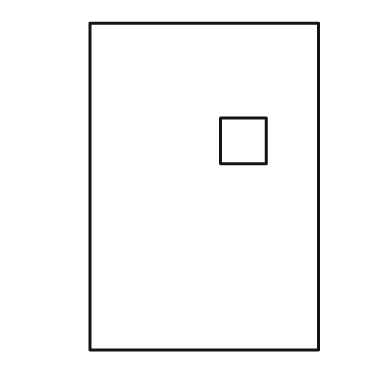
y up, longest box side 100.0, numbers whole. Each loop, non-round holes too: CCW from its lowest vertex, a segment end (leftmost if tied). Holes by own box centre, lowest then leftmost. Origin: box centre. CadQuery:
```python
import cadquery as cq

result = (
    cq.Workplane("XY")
    .moveTo(-35.0, -50.0)
    .lineTo(35.0, -50.0)
    .lineTo(35.0, 50.0)
    .lineTo(-35.0, 50.0)
    .close()
    .moveTo(5.0, 7.0)
    .lineTo(19.0, 7.0)
    .lineTo(19.0, 21.0)
    .lineTo(5.0, 21.0)
    .close()
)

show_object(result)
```